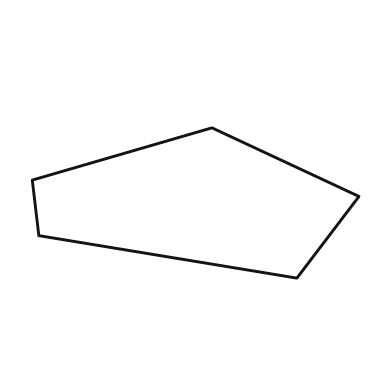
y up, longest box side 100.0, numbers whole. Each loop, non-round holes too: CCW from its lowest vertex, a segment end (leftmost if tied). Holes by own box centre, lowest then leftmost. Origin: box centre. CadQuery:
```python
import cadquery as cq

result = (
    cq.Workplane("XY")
    .moveTo(31.0, -23.0)
    .lineTo(50.0, 2.0)
    .lineTo(5.0, 23.0)
    .lineTo(-50.0, 7.0)
    .lineTo(-48.0, -10.0)
    .close()
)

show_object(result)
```